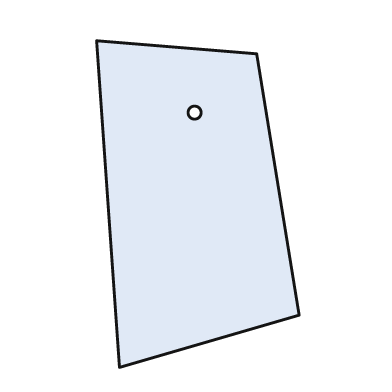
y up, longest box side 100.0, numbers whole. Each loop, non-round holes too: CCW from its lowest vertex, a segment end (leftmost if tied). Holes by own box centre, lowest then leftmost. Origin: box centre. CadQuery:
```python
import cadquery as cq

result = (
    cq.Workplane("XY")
    .moveTo(-24.0, -50.0)
    .lineTo(31.0, -34.0)
    .lineTo(18.0, 46.0)
    .lineTo(-31.0, 50.0)
    .close()
    .moveTo(-1.0, 28.0)
    .circle(2.0)
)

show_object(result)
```